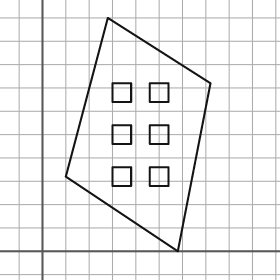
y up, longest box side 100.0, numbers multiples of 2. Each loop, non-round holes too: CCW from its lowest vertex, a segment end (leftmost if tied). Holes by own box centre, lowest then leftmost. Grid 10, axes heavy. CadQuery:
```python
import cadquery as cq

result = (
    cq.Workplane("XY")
    .moveTo(58.0, 0.0)
    .lineTo(72.0, 72.0)
    .lineTo(28.0, 100.0)
    .lineTo(10.0, 32.0)
    .close()
    .moveTo(30.0, 28.0)
    .lineTo(38.0, 28.0)
    .lineTo(38.0, 36.0)
    .lineTo(30.0, 36.0)
    .close()
    .moveTo(46.0, 28.0)
    .lineTo(54.0, 28.0)
    .lineTo(54.0, 36.0)
    .lineTo(46.0, 36.0)
    .close()
    .moveTo(30.0, 46.0)
    .lineTo(38.0, 46.0)
    .lineTo(38.0, 54.0)
    .lineTo(30.0, 54.0)
    .close()
    .moveTo(46.0, 46.0)
    .lineTo(54.0, 46.0)
    .lineTo(54.0, 54.0)
    .lineTo(46.0, 54.0)
    .close()
    .moveTo(30.0, 64.0)
    .lineTo(38.0, 64.0)
    .lineTo(38.0, 72.0)
    .lineTo(30.0, 72.0)
    .close()
    .moveTo(46.0, 64.0)
    .lineTo(54.0, 64.0)
    .lineTo(54.0, 72.0)
    .lineTo(46.0, 72.0)
    .close()
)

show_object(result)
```